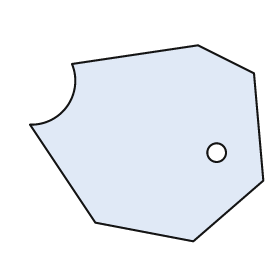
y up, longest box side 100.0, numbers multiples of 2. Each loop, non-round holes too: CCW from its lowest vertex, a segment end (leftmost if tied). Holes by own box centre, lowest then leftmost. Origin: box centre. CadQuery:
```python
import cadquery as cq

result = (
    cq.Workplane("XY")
    .moveTo(20.0, -42.0)
    .lineTo(50.0, -16.0)
    .lineTo(46.0, 30.0)
    .lineTo(22.0, 42.0)
    .lineTo(-32.0, 34.0)
    .threePointArc((-34.0, 16.0), (-50.0, 8.0))
    .lineTo(-22.0, -34.0)
    .close()
    .moveTo(30.0, -4.0)
    .circle(4.0)
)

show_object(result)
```